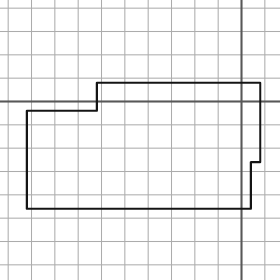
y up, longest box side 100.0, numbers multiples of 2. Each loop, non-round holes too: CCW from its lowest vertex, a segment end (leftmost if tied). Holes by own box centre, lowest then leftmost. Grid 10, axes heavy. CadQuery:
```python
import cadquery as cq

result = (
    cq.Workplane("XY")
    .moveTo(-92.0, -46.0)
    .lineTo(4.0, -46.0)
    .lineTo(4.0, -26.0)
    .lineTo(8.0, -26.0)
    .lineTo(8.0, 8.0)
    .lineTo(-62.0, 8.0)
    .lineTo(-62.0, -4.0)
    .lineTo(-92.0, -4.0)
    .close()
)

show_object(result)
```